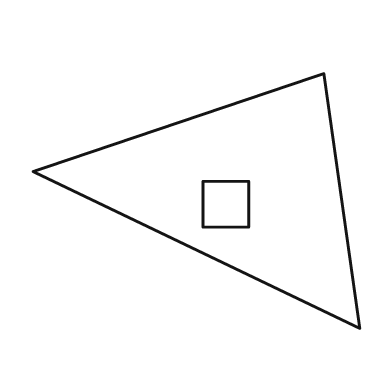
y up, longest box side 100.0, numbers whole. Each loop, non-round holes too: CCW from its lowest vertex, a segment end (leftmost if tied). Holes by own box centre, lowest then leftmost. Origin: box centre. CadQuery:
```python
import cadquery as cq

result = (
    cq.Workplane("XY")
    .moveTo(50.0, -39.0)
    .lineTo(39.0, 39.0)
    .lineTo(-50.0, 9.0)
    .close()
    .moveTo(2.0, -8.0)
    .lineTo(16.0, -8.0)
    .lineTo(16.0, 6.0)
    .lineTo(2.0, 6.0)
    .close()
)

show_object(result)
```